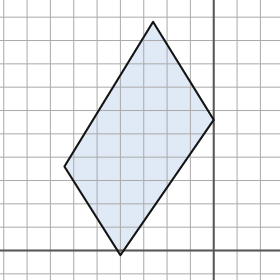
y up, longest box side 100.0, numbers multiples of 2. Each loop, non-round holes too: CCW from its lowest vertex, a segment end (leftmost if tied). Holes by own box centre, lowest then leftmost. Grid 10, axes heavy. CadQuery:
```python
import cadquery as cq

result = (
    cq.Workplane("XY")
    .moveTo(-40.0, -2.0)
    .lineTo(0.0, 56.0)
    .lineTo(-26.0, 98.0)
    .lineTo(-64.0, 36.0)
    .close()
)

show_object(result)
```